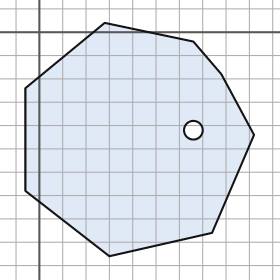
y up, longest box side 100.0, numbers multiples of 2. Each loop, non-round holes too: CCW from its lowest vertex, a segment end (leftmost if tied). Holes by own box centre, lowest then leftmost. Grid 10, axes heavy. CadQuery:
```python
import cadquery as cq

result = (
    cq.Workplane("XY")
    .moveTo(30.0, -96.0)
    .lineTo(74.0, -86.0)
    .lineTo(92.0, -44.0)
    .lineTo(78.0, -18.0)
    .lineTo(66.0, -4.0)
    .lineTo(28.0, 4.0)
    .lineTo(-6.0, -24.0)
    .lineTo(-6.0, -68.0)
    .close()
    .moveTo(66.0, -42.0)
    .circle(4.0)
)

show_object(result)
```